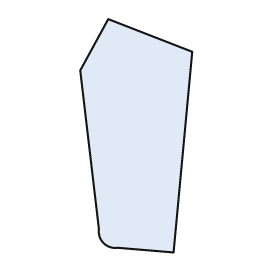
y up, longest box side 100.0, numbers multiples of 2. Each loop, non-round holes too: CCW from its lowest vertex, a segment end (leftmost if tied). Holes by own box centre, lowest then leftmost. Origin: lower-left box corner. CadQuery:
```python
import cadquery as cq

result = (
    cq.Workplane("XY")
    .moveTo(40.0, 0.0)
    .lineTo(48.0, 86.0)
    .lineTo(12.0, 100.0)
    .lineTo(0.0, 78.0)
    .lineTo(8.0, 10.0)
    .threePointArc((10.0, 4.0), (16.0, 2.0))
    .close()
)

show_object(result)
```